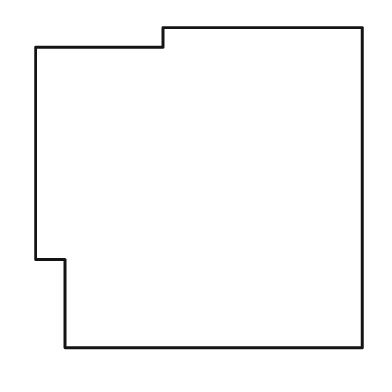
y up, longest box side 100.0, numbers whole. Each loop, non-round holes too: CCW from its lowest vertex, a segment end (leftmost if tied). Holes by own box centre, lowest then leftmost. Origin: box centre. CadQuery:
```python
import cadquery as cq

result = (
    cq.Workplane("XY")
    .moveTo(-41.0, -49.0)
    .lineTo(50.0, -49.0)
    .lineTo(50.0, 49.0)
    .lineTo(-11.0, 49.0)
    .lineTo(-11.0, 43.0)
    .lineTo(-50.0, 43.0)
    .lineTo(-50.0, -22.0)
    .lineTo(-41.0, -22.0)
    .close()
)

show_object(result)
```